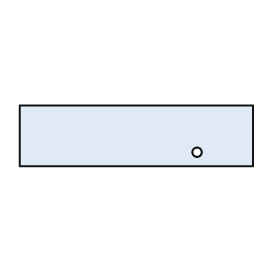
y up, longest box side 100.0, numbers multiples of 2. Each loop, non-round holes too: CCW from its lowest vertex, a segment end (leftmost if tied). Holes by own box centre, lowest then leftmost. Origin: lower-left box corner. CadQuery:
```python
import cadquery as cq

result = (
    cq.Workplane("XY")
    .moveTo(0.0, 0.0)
    .lineTo(100.0, 0.0)
    .lineTo(100.0, 26.0)
    .lineTo(0.0, 26.0)
    .close()
    .moveTo(76.0, 6.0)
    .circle(2.0)
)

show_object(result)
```